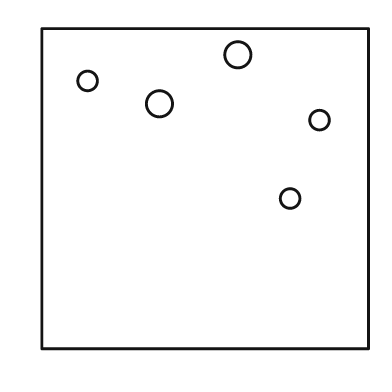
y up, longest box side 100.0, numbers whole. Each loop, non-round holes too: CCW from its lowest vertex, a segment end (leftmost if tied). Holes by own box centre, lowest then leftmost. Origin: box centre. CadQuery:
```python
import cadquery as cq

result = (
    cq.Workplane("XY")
    .moveTo(-50.0, -49.0)
    .lineTo(50.0, -49.0)
    .lineTo(50.0, 49.0)
    .lineTo(-50.0, 49.0)
    .close()
    .moveTo(26.0, -3.0)
    .circle(3.0)
    .moveTo(35.0, 21.0)
    .circle(3.0)
    .moveTo(-14.0, 26.0)
    .circle(4.0)
    .moveTo(-36.0, 33.0)
    .circle(3.0)
    .moveTo(10.0, 41.0)
    .circle(4.0)
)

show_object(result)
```